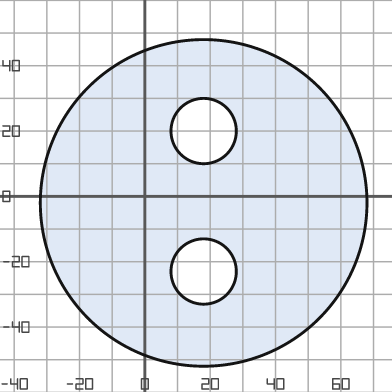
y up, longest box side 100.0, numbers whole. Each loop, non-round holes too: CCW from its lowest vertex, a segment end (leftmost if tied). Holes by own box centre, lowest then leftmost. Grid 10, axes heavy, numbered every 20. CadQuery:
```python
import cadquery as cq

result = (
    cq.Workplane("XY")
    .moveTo(18.0, -2.0)
    .circle(50.0)
    .moveTo(18.0, -23.0)
    .circle(10.0)
    .moveTo(18.0, 20.0)
    .circle(10.0)
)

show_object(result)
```